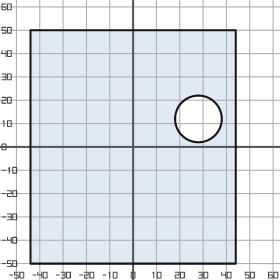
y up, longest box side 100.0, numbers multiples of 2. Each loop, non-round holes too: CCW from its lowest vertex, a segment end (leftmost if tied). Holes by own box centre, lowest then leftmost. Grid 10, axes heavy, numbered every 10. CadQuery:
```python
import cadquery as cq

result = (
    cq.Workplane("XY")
    .moveTo(-44.0, -50.0)
    .lineTo(44.0, -50.0)
    .lineTo(44.0, 50.0)
    .lineTo(-44.0, 50.0)
    .close()
    .moveTo(28.0, 12.0)
    .circle(10.0)
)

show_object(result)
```